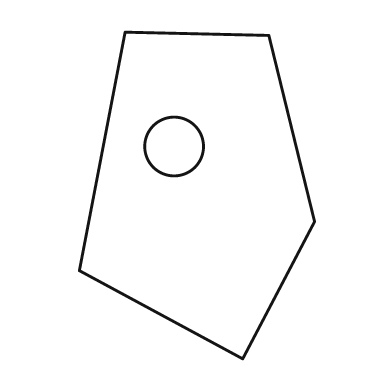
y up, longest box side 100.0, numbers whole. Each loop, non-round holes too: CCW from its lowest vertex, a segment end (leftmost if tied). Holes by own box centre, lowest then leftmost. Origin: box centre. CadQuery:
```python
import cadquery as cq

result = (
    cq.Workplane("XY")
    .moveTo(14.0, -50.0)
    .lineTo(36.0, -8.0)
    .lineTo(22.0, 49.0)
    .lineTo(-22.0, 50.0)
    .lineTo(-36.0, -23.0)
    .close()
    .moveTo(-7.0, 15.0)
    .circle(9.0)
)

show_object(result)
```